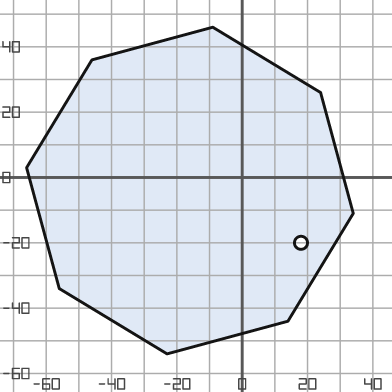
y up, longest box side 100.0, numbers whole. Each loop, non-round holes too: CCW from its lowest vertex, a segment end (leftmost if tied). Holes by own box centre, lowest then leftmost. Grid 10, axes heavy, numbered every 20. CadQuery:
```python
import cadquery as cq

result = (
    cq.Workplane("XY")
    .moveTo(-23.0, -54.0)
    .lineTo(14.0, -44.0)
    .lineTo(34.0, -11.0)
    .lineTo(24.0, 26.0)
    .lineTo(-9.0, 46.0)
    .lineTo(-46.0, 36.0)
    .lineTo(-66.0, 3.0)
    .lineTo(-56.0, -34.0)
    .close()
    .moveTo(18.0, -20.0)
    .circle(2.0)
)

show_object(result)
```